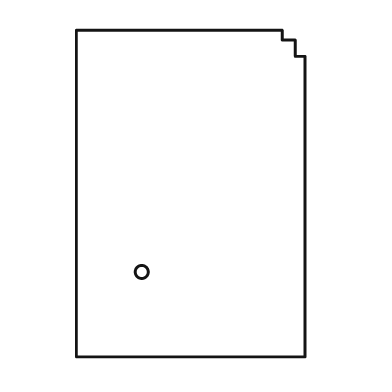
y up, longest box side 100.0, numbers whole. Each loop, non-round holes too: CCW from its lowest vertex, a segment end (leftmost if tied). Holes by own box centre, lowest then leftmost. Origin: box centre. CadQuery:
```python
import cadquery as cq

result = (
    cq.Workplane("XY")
    .moveTo(-35.0, -50.0)
    .lineTo(35.0, -50.0)
    .lineTo(35.0, 42.0)
    .lineTo(32.0, 42.0)
    .lineTo(32.0, 47.0)
    .lineTo(28.0, 47.0)
    .lineTo(28.0, 50.0)
    .lineTo(-35.0, 50.0)
    .close()
    .moveTo(-15.0, -24.0)
    .circle(2.0)
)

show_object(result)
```